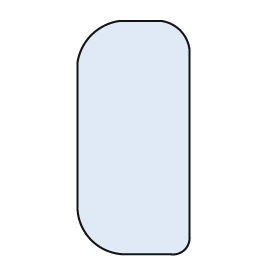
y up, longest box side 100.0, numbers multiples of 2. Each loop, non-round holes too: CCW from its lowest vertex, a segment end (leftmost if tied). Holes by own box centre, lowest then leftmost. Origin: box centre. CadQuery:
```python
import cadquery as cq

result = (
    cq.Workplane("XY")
    .moveTo(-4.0, -50.0)
    .lineTo(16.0, -50.0)
    .threePointArc((22.0, -48.0), (24.0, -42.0))
    .lineTo(24.0, 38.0)
    .threePointArc((20.0, 46.0), (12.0, 50.0))
    .lineTo(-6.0, 50.0)
    .threePointArc((-18.0, 44.0), (-24.0, 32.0))
    .lineTo(-24.0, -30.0)
    .threePointArc((-18.0, -44.0), (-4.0, -50.0))
    .close()
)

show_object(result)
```